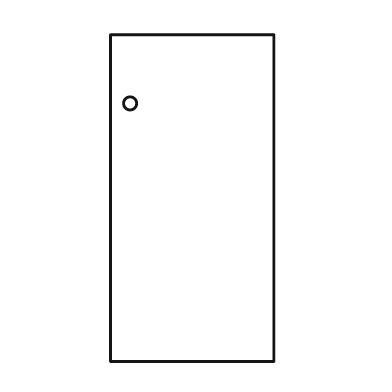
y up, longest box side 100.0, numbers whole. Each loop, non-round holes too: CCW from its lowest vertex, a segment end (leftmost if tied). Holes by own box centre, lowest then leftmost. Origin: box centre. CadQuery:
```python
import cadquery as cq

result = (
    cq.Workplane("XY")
    .moveTo(-25.0, -50.0)
    .lineTo(25.0, -50.0)
    .lineTo(25.0, 50.0)
    .lineTo(-25.0, 50.0)
    .close()
    .moveTo(-19.0, 29.0)
    .circle(2.0)
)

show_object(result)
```